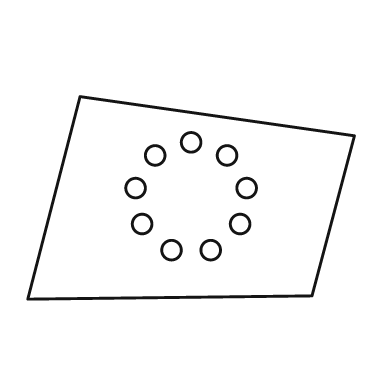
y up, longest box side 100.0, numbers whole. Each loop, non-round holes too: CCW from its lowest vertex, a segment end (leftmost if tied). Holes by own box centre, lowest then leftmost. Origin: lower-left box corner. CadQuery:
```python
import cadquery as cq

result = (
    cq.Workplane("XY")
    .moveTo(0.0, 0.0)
    .lineTo(87.0, 1.0)
    .lineTo(100.0, 50.0)
    .lineTo(16.0, 62.0)
    .close()
    .moveTo(44.0, 15.0)
    .circle(3.0)
    .moveTo(56.0, 15.0)
    .circle(3.0)
    .moveTo(35.0, 23.0)
    .circle(3.0)
    .moveTo(65.0, 23.0)
    .circle(3.0)
    .moveTo(33.0, 34.0)
    .circle(3.0)
    .moveTo(67.0, 34.0)
    .circle(3.0)
    .moveTo(39.0, 44.0)
    .circle(3.0)
    .moveTo(61.0, 44.0)
    .circle(3.0)
    .moveTo(50.0, 48.0)
    .circle(3.0)
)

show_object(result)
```